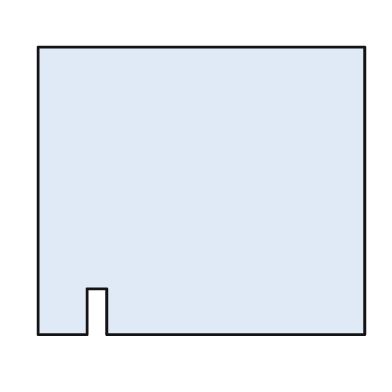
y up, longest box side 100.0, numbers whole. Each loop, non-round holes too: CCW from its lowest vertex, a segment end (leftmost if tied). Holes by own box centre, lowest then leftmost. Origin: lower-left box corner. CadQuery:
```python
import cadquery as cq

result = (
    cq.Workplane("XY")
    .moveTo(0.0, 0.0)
    .lineTo(15.0, 0.0)
    .lineTo(15.0, 14.0)
    .lineTo(21.0, 14.0)
    .lineTo(21.0, 0.0)
    .lineTo(100.0, 0.0)
    .lineTo(100.0, 88.0)
    .lineTo(0.0, 88.0)
    .close()
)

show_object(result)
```